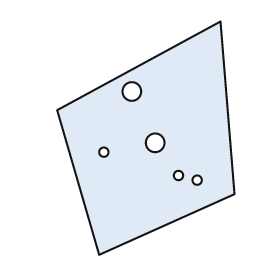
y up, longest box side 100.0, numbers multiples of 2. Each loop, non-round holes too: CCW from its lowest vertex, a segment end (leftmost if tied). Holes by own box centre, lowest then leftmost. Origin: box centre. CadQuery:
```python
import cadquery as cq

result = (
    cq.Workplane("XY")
    .moveTo(-20.0, -50.0)
    .lineTo(38.0, -24.0)
    .lineTo(32.0, 50.0)
    .lineTo(-38.0, 12.0)
    .close()
    .moveTo(22.0, -18.0)
    .circle(2.0)
    .moveTo(14.0, -16.0)
    .circle(2.0)
    .moveTo(-18.0, -6.0)
    .circle(2.0)
    .moveTo(4.0, -2.0)
    .circle(4.0)
    .moveTo(-6.0, 20.0)
    .circle(4.0)
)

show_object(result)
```